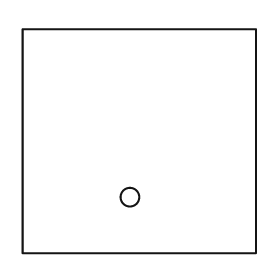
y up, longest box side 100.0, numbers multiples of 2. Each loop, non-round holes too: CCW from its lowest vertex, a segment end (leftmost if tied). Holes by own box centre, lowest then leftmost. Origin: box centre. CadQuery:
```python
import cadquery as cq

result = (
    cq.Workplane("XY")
    .moveTo(-50.0, -48.0)
    .lineTo(50.0, -48.0)
    .lineTo(50.0, 48.0)
    .lineTo(-50.0, 48.0)
    .close()
    .moveTo(-4.0, -24.0)
    .circle(4.0)
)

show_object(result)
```